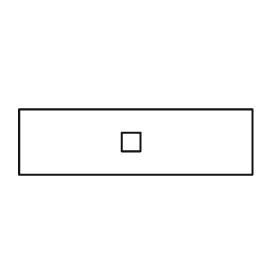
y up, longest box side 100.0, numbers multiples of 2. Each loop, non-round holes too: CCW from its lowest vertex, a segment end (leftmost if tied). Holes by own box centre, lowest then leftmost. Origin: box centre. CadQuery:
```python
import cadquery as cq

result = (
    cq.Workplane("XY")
    .moveTo(-50.0, -14.0)
    .lineTo(50.0, -14.0)
    .lineTo(50.0, 14.0)
    .lineTo(-50.0, 14.0)
    .close()
    .moveTo(-6.0, -4.0)
    .lineTo(2.0, -4.0)
    .lineTo(2.0, 4.0)
    .lineTo(-6.0, 4.0)
    .close()
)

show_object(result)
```